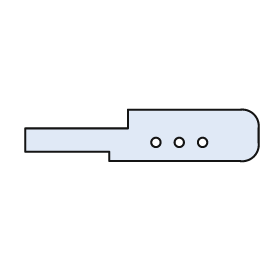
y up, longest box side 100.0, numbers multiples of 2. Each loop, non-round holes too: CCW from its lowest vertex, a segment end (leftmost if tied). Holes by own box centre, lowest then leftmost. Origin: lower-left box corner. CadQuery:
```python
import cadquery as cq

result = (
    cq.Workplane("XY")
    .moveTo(36.0, 0.0)
    .lineTo(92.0, 0.0)
    .threePointArc((98.0, 2.0), (100.0, 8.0))
    .lineTo(100.0, 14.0)
    .threePointArc((98.0, 20.0), (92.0, 22.0))
    .lineTo(44.0, 22.0)
    .lineTo(44.0, 14.0)
    .lineTo(0.0, 14.0)
    .lineTo(0.0, 4.0)
    .lineTo(36.0, 4.0)
    .close()
    .moveTo(56.0, 8.0)
    .circle(2.0)
    .moveTo(66.0, 8.0)
    .circle(2.0)
    .moveTo(76.0, 8.0)
    .circle(2.0)
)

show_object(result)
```